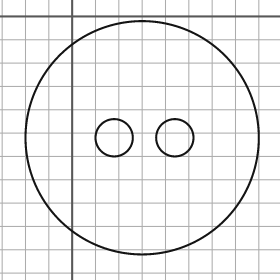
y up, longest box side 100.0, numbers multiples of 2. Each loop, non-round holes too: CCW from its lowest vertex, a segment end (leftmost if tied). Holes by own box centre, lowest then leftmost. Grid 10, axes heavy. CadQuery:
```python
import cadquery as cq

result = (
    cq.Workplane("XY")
    .moveTo(30.0, -52.0)
    .circle(50.0)
    .moveTo(18.0, -52.0)
    .circle(8.0)
    .moveTo(44.0, -52.0)
    .circle(8.0)
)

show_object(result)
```